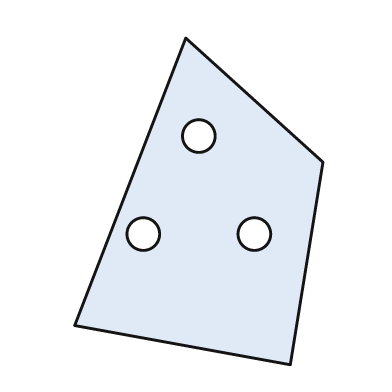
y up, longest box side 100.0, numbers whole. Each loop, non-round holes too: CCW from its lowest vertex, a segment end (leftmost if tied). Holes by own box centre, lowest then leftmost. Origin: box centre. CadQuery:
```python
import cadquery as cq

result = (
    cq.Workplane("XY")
    .moveTo(28.0, -50.0)
    .lineTo(38.0, 12.0)
    .lineTo(-4.0, 50.0)
    .lineTo(-38.0, -38.0)
    .close()
    .moveTo(-17.0, -10.0)
    .circle(5.0)
    .moveTo(17.0, -10.0)
    .circle(5.0)
    .moveTo(0.0, 20.0)
    .circle(5.0)
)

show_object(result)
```